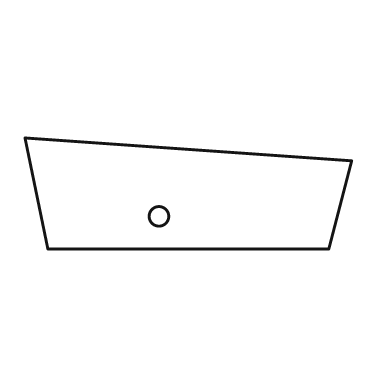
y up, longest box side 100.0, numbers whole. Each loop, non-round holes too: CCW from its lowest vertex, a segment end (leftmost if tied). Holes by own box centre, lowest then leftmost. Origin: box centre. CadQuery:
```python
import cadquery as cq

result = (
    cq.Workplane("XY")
    .moveTo(-43.0, -17.0)
    .lineTo(43.0, -17.0)
    .lineTo(50.0, 10.0)
    .lineTo(-50.0, 17.0)
    .close()
    .moveTo(-9.0, -7.0)
    .circle(3.0)
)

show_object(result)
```